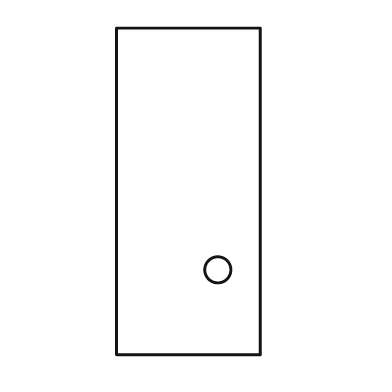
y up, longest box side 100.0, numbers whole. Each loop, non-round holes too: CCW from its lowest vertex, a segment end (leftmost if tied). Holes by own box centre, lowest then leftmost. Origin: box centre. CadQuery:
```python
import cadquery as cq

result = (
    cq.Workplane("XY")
    .moveTo(-22.0, -50.0)
    .lineTo(22.0, -50.0)
    .lineTo(22.0, 50.0)
    .lineTo(-22.0, 50.0)
    .close()
    .moveTo(9.0, -24.0)
    .circle(4.0)
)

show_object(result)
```